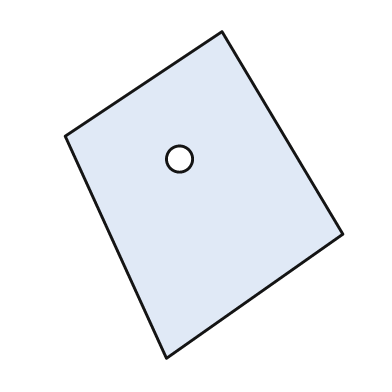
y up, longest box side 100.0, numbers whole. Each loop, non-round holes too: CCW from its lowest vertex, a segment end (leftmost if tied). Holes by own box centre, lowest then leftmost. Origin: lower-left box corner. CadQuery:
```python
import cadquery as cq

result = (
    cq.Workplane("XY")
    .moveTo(31.0, 0.0)
    .lineTo(85.0, 38.0)
    .lineTo(48.0, 100.0)
    .lineTo(0.0, 68.0)
    .close()
    .moveTo(35.0, 61.0)
    .circle(4.0)
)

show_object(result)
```